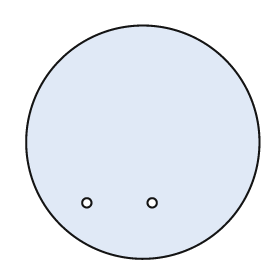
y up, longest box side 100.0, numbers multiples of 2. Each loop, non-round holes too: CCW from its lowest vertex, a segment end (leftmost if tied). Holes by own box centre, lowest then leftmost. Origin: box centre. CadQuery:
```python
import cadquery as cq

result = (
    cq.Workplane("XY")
    .moveTo(0.0, 0.0)
    .circle(50.0)
    .moveTo(-24.0, -26.0)
    .circle(2.0)
    .moveTo(4.0, -26.0)
    .circle(2.0)
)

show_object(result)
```